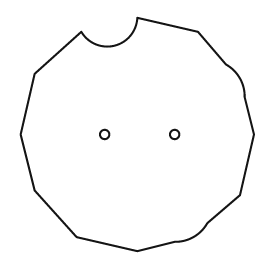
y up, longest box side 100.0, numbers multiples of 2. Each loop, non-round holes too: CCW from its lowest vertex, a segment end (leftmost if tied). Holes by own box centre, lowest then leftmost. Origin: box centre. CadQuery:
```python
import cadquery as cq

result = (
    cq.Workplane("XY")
    .moveTo(0.0, -50.0)
    .lineTo(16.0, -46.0)
    .threePointArc((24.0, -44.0), (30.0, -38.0))
    .lineTo(44.0, -26.0)
    .lineTo(50.0, 0.0)
    .lineTo(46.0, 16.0)
    .threePointArc((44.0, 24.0), (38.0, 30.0))
    .lineTo(26.0, 44.0)
    .lineTo(0.0, 50.0)
    .threePointArc((-10.0, 38.0), (-24.0, 44.0))
    .lineTo(-44.0, 26.0)
    .lineTo(-50.0, 0.0)
    .lineTo(-44.0, -24.0)
    .lineTo(-26.0, -44.0)
    .close()
    .moveTo(-14.0, 0.0)
    .circle(2.0)
    .moveTo(16.0, 0.0)
    .circle(2.0)
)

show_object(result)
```